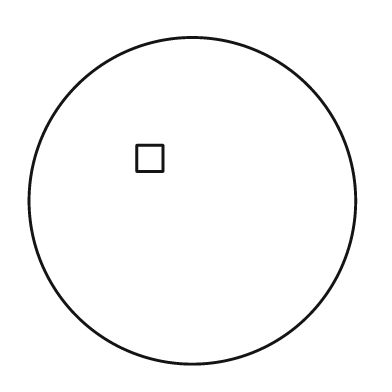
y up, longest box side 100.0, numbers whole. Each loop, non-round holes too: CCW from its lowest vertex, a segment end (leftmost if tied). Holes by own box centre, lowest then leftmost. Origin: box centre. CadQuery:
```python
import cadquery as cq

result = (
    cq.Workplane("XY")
    .moveTo(0.0, 0.0)
    .circle(50.0)
    .moveTo(-17.0, 9.0)
    .lineTo(-9.0, 9.0)
    .lineTo(-9.0, 17.0)
    .lineTo(-17.0, 17.0)
    .close()
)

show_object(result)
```